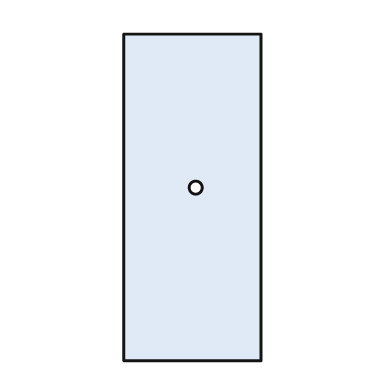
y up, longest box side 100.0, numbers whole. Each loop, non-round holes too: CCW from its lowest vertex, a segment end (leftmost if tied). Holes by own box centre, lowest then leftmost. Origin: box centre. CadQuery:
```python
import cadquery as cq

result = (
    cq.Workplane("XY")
    .moveTo(-21.0, -50.0)
    .lineTo(21.0, -50.0)
    .lineTo(21.0, 50.0)
    .lineTo(-21.0, 50.0)
    .close()
    .moveTo(1.0, 3.0)
    .circle(2.0)
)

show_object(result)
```